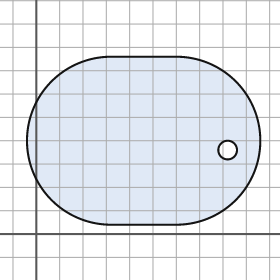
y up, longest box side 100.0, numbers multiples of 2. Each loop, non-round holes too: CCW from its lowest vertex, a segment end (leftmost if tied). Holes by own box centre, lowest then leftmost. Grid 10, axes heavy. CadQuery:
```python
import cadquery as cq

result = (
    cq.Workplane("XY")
    .moveTo(32.0, 4.0)
    .lineTo(60.0, 4.0)
    .threePointArc((96.0, 40.0), (60.0, 76.0))
    .lineTo(32.0, 76.0)
    .threePointArc((-4.0, 40.0), (32.0, 4.0))
    .close()
    .moveTo(82.0, 36.0)
    .circle(4.0)
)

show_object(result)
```